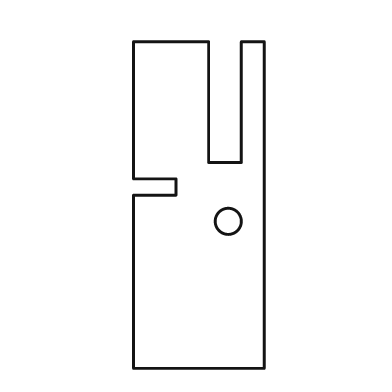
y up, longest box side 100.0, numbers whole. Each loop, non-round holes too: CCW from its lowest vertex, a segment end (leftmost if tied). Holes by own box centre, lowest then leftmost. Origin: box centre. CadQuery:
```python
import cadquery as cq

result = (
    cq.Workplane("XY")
    .moveTo(-20.0, -50.0)
    .lineTo(20.0, -50.0)
    .lineTo(20.0, 50.0)
    .lineTo(13.0, 50.0)
    .lineTo(13.0, 13.0)
    .lineTo(3.0, 13.0)
    .lineTo(3.0, 50.0)
    .lineTo(-20.0, 50.0)
    .lineTo(-20.0, 8.0)
    .lineTo(-7.0, 8.0)
    .lineTo(-7.0, 3.0)
    .lineTo(-20.0, 3.0)
    .close()
    .moveTo(9.0, -5.0)
    .circle(4.0)
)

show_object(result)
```